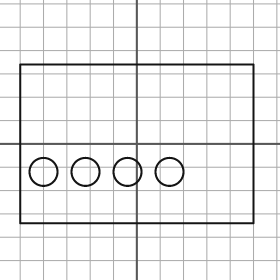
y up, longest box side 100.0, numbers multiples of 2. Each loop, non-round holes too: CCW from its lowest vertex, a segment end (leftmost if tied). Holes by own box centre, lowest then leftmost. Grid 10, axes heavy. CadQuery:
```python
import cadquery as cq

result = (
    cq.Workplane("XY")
    .moveTo(-50.0, -34.0)
    .lineTo(50.0, -34.0)
    .lineTo(50.0, 34.0)
    .lineTo(-50.0, 34.0)
    .close()
    .moveTo(-40.0, -12.0)
    .circle(6.0)
    .moveTo(-22.0, -12.0)
    .circle(6.0)
    .moveTo(-4.0, -12.0)
    .circle(6.0)
    .moveTo(14.0, -12.0)
    .circle(6.0)
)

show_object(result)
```